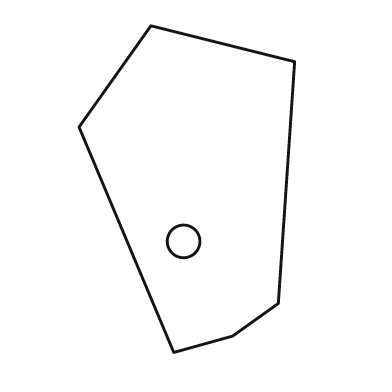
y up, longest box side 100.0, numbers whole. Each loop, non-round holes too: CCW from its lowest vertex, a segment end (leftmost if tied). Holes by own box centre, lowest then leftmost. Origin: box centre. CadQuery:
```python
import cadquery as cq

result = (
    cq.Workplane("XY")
    .moveTo(-4.0, -50.0)
    .lineTo(14.0, -45.0)
    .lineTo(28.0, -35.0)
    .lineTo(33.0, 39.0)
    .lineTo(-11.0, 50.0)
    .lineTo(-33.0, 19.0)
    .close()
    .moveTo(-1.0, -16.0)
    .circle(5.0)
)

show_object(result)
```